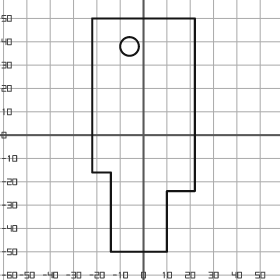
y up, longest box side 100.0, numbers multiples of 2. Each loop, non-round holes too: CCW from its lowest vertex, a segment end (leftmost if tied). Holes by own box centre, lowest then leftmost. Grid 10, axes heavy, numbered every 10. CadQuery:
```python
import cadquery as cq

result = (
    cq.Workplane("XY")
    .moveTo(-14.0, -50.0)
    .lineTo(10.0, -50.0)
    .lineTo(10.0, -24.0)
    .lineTo(22.0, -24.0)
    .lineTo(22.0, 50.0)
    .lineTo(-22.0, 50.0)
    .lineTo(-22.0, -16.0)
    .lineTo(-14.0, -16.0)
    .close()
    .moveTo(-6.0, 38.0)
    .circle(4.0)
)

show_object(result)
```